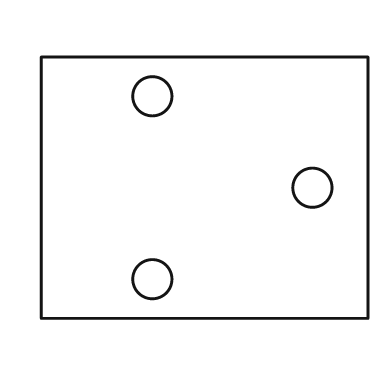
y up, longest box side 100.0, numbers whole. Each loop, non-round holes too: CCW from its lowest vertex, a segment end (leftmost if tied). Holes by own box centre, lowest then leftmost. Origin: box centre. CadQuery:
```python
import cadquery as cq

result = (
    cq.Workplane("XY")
    .moveTo(-50.0, -40.0)
    .lineTo(50.0, -40.0)
    .lineTo(50.0, 40.0)
    .lineTo(-50.0, 40.0)
    .close()
    .moveTo(-16.0, -28.0)
    .circle(6.0)
    .moveTo(33.0, 0.0)
    .circle(6.0)
    .moveTo(-16.0, 28.0)
    .circle(6.0)
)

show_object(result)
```